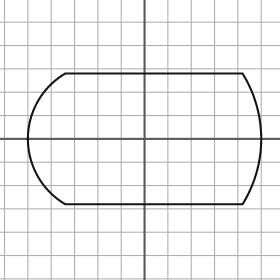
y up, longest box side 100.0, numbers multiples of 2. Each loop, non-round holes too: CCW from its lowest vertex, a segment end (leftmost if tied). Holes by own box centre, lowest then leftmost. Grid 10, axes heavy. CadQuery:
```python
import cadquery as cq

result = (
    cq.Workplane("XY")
    .moveTo(-34.0, -28.0)
    .lineTo(42.0, -28.0)
    .threePointArc((50.0, 0.0), (42.0, 28.0))
    .lineTo(-34.0, 28.0)
    .threePointArc((-50.0, 0.0), (-34.0, -28.0))
    .close()
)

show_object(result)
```